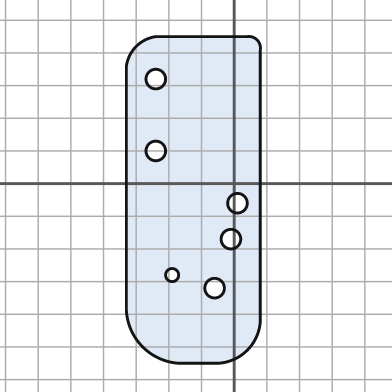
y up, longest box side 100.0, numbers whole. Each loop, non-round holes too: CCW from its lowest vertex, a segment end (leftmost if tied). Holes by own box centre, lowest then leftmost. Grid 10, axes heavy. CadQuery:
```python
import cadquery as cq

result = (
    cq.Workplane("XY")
    .moveTo(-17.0, -55.0)
    .lineTo(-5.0, -55.0)
    .threePointArc((4.0, -51.0), (8.0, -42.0))
    .lineTo(8.0, 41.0)
    .threePointArc((7.0, 44.0), (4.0, 45.0))
    .lineTo(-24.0, 45.0)
    .threePointArc((-30.0, 42.0), (-33.0, 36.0))
    .lineTo(-33.0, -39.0)
    .threePointArc((-28.0, -50.0), (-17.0, -55.0))
    .close()
    .moveTo(-6.0, -32.0)
    .circle(3.0)
    .moveTo(-19.0, -28.0)
    .circle(2.0)
    .moveTo(-1.0, -17.0)
    .circle(3.0)
    .moveTo(1.0, -6.0)
    .circle(3.0)
    .moveTo(-24.0, 10.0)
    .circle(3.0)
    .moveTo(-24.0, 32.0)
    .circle(3.0)
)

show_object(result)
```